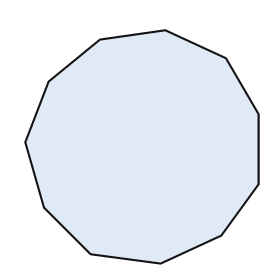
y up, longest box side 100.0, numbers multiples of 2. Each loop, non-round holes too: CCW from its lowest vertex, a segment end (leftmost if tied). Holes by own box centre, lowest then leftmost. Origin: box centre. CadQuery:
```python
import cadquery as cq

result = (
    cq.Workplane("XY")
    .moveTo(8.0, -50.0)
    .lineTo(34.0, -38.0)
    .lineTo(50.0, -16.0)
    .lineTo(50.0, 14.0)
    .lineTo(36.0, 38.0)
    .lineTo(10.0, 50.0)
    .lineTo(-18.0, 46.0)
    .lineTo(-40.0, 28.0)
    .lineTo(-50.0, 2.0)
    .lineTo(-42.0, -26.0)
    .lineTo(-22.0, -46.0)
    .close()
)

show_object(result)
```